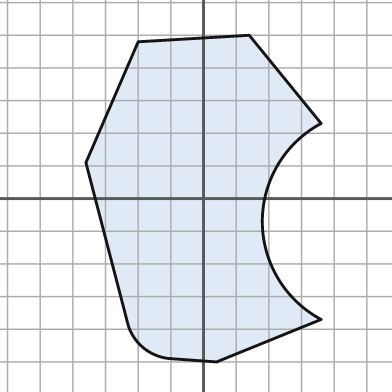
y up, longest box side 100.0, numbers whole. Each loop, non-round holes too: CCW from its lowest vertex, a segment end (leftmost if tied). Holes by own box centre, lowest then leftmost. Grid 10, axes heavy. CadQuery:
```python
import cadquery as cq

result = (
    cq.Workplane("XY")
    .moveTo(4.0, -50.0)
    .lineTo(36.0, -37.0)
    .threePointArc((18.0, -7.0), (36.0, 23.0))
    .lineTo(14.0, 50.0)
    .lineTo(-20.0, 48.0)
    .lineTo(-36.0, 11.0)
    .lineTo(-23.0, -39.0)
    .threePointArc((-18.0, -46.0), (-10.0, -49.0))
    .close()
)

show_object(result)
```